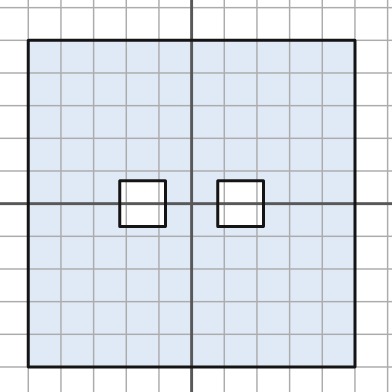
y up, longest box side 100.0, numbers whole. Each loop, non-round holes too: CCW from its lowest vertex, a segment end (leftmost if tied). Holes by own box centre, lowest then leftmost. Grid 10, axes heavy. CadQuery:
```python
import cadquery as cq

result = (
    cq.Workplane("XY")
    .moveTo(-50.0, -50.0)
    .lineTo(50.0, -50.0)
    .lineTo(50.0, 50.0)
    .lineTo(-50.0, 50.0)
    .close()
    .moveTo(-22.0, -7.0)
    .lineTo(-8.0, -7.0)
    .lineTo(-8.0, 7.0)
    .lineTo(-22.0, 7.0)
    .close()
    .moveTo(8.0, -7.0)
    .lineTo(22.0, -7.0)
    .lineTo(22.0, 7.0)
    .lineTo(8.0, 7.0)
    .close()
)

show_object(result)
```